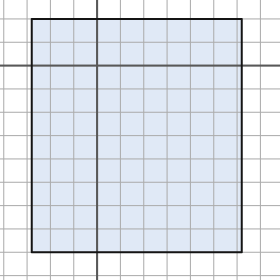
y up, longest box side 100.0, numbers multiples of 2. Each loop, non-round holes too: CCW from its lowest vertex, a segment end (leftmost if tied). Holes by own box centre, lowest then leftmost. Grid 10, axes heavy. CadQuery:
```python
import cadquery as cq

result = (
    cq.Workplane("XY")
    .moveTo(-28.0, -80.0)
    .lineTo(62.0, -80.0)
    .lineTo(62.0, 20.0)
    .lineTo(-28.0, 20.0)
    .close()
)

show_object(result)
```